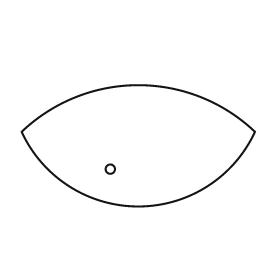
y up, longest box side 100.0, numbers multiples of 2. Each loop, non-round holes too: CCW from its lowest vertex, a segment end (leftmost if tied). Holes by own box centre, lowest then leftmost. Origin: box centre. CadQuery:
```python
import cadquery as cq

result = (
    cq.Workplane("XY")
    .moveTo(-50.0, 6.0)
    .threePointArc((0.0, -26.0), (50.0, 6.0))
    .threePointArc((0.0, 26.0), (-50.0, 6.0))
    .close()
    .moveTo(-12.0, -10.0)
    .circle(2.0)
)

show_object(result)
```